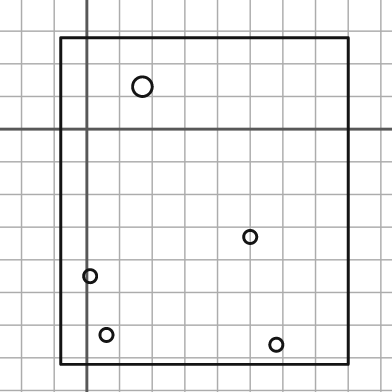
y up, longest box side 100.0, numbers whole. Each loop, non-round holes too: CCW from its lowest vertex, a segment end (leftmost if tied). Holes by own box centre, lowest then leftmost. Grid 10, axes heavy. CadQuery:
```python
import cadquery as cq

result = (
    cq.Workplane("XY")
    .moveTo(-8.0, -72.0)
    .lineTo(80.0, -72.0)
    .lineTo(80.0, 28.0)
    .lineTo(-8.0, 28.0)
    .close()
    .moveTo(58.0, -66.0)
    .circle(2.0)
    .moveTo(6.0, -63.0)
    .circle(2.0)
    .moveTo(1.0, -45.0)
    .circle(2.0)
    .moveTo(50.0, -33.0)
    .circle(2.0)
    .moveTo(17.0, 13.0)
    .circle(3.0)
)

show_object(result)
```